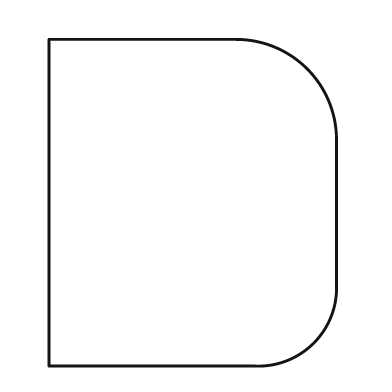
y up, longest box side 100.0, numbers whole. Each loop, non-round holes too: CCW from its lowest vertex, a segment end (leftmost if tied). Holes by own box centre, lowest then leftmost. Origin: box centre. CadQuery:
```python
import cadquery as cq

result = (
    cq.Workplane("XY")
    .moveTo(-44.0, -50.0)
    .lineTo(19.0, -50.0)
    .threePointArc((37.0, -43.0), (44.0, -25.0))
    .lineTo(44.0, 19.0)
    .threePointArc((35.0, 41.0), (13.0, 50.0))
    .lineTo(-44.0, 50.0)
    .close()
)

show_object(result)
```